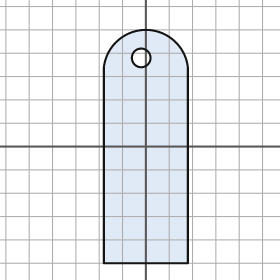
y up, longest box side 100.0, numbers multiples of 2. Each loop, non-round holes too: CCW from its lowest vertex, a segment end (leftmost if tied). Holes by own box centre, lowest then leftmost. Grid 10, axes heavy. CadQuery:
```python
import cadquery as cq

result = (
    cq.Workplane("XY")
    .moveTo(-18.0, -50.0)
    .lineTo(18.0, -50.0)
    .lineTo(18.0, 34.0)
    .threePointArc((0.0, 50.0), (-18.0, 34.0))
    .close()
    .moveTo(-2.0, 38.0)
    .circle(4.0)
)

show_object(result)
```